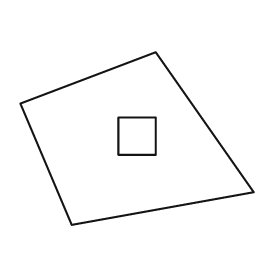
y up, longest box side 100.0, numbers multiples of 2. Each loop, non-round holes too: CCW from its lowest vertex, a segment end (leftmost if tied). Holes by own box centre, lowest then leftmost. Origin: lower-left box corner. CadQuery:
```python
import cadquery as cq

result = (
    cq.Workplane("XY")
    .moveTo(22.0, 0.0)
    .lineTo(100.0, 14.0)
    .lineTo(58.0, 74.0)
    .lineTo(0.0, 52.0)
    .close()
    .moveTo(42.0, 30.0)
    .lineTo(58.0, 30.0)
    .lineTo(58.0, 46.0)
    .lineTo(42.0, 46.0)
    .close()
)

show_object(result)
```